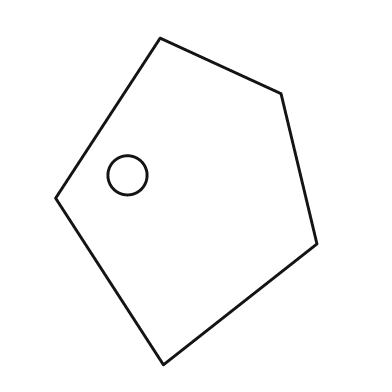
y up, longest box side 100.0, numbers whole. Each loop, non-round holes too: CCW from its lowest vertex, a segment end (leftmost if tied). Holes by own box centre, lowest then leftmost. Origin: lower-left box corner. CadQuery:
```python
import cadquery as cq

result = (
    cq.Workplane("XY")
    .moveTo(33.0, 0.0)
    .lineTo(80.0, 37.0)
    .lineTo(69.0, 83.0)
    .lineTo(32.0, 100.0)
    .lineTo(0.0, 51.0)
    .close()
    .moveTo(22.0, 58.0)
    .circle(6.0)
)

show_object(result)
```